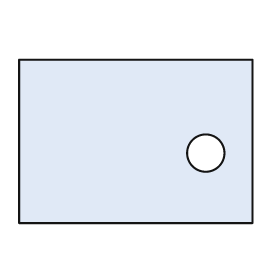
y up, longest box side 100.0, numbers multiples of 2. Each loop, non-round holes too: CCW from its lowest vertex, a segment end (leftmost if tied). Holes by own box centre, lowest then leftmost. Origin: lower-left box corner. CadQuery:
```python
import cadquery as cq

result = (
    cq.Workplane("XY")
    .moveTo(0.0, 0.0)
    .lineTo(100.0, 0.0)
    .lineTo(100.0, 70.0)
    .lineTo(0.0, 70.0)
    .close()
    .moveTo(80.0, 30.0)
    .circle(8.0)
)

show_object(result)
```